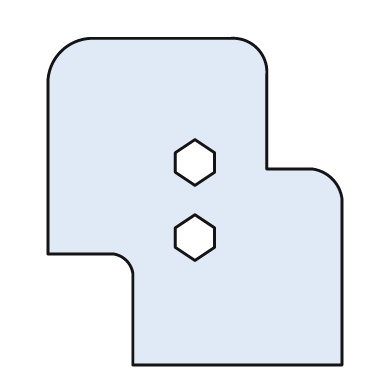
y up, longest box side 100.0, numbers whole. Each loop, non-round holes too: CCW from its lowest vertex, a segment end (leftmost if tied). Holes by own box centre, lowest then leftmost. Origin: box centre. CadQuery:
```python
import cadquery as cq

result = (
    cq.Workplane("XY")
    .moveTo(-19.0, -50.0)
    .lineTo(45.0, -50.0)
    .lineTo(45.0, 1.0)
    .threePointArc((42.0, 7.0), (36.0, 10.0))
    .lineTo(22.0, 10.0)
    .lineTo(22.0, 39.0)
    .threePointArc((19.0, 47.0), (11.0, 50.0))
    .lineTo(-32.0, 50.0)
    .threePointArc((-41.0, 46.0), (-45.0, 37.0))
    .lineTo(-45.0, -16.0)
    .lineTo(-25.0, -16.0)
    .threePointArc((-21.0, -18.0), (-19.0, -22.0))
    .close()
    .moveTo(0.0, -18.0)
    .lineTo(6.0, -14.0)
    .lineTo(6.0, -8.0)
    .lineTo(0.0, -4.0)
    .lineTo(-6.0, -8.0)
    .lineTo(-6.0, -14.0)
    .close()
    .moveTo(0.0, 5.0)
    .lineTo(6.0, 9.0)
    .lineTo(6.0, 15.0)
    .lineTo(0.0, 19.0)
    .lineTo(-6.0, 15.0)
    .lineTo(-6.0, 9.0)
    .close()
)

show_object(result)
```